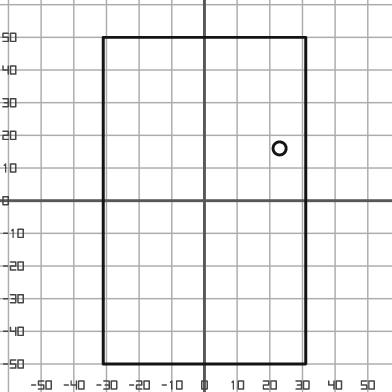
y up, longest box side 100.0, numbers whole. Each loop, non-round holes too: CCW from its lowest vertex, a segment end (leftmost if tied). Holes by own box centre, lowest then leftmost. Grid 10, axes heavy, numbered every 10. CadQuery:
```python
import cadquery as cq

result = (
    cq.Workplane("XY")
    .moveTo(-31.0, -50.0)
    .lineTo(31.0, -50.0)
    .lineTo(31.0, 50.0)
    .lineTo(-31.0, 50.0)
    .close()
    .moveTo(23.0, 16.0)
    .circle(2.0)
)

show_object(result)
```